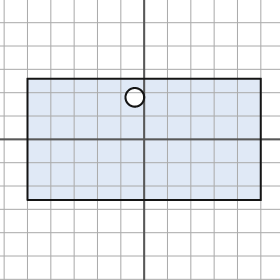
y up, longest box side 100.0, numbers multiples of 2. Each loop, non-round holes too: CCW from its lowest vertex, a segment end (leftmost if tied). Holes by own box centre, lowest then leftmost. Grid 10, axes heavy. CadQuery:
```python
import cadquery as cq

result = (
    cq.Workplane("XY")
    .moveTo(-50.0, -26.0)
    .lineTo(50.0, -26.0)
    .lineTo(50.0, 26.0)
    .lineTo(-50.0, 26.0)
    .close()
    .moveTo(-4.0, 18.0)
    .circle(4.0)
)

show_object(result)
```